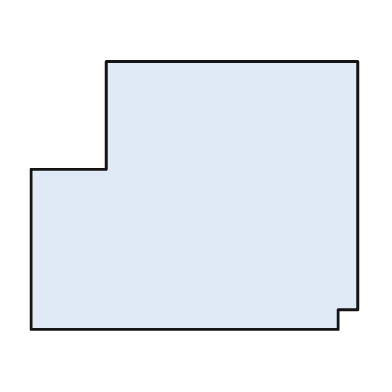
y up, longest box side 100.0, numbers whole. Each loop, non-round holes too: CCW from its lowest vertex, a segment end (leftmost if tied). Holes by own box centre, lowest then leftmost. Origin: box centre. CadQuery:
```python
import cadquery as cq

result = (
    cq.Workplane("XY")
    .moveTo(-50.0, -41.0)
    .lineTo(44.0, -41.0)
    .lineTo(44.0, -35.0)
    .lineTo(50.0, -35.0)
    .lineTo(50.0, 41.0)
    .lineTo(-27.0, 41.0)
    .lineTo(-27.0, 8.0)
    .lineTo(-50.0, 8.0)
    .close()
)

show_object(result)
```